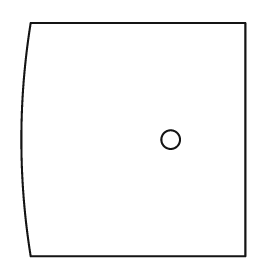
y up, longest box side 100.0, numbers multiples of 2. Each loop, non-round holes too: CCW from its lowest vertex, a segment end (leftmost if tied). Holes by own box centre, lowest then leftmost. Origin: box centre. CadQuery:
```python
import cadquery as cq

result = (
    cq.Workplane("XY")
    .moveTo(-44.0, -50.0)
    .lineTo(48.0, -50.0)
    .lineTo(48.0, 50.0)
    .lineTo(-44.0, 50.0)
    .threePointArc((-48.0, 0.0), (-44.0, -50.0))
    .close()
    .moveTo(16.0, 0.0)
    .circle(4.0)
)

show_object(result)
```